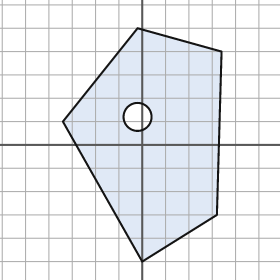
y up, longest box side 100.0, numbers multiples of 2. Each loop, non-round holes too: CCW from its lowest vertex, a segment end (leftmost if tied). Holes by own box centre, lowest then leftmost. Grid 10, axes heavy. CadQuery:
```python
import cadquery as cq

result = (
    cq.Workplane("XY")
    .moveTo(0.0, -50.0)
    .lineTo(32.0, -30.0)
    .lineTo(34.0, 40.0)
    .lineTo(-2.0, 50.0)
    .lineTo(-34.0, 10.0)
    .close()
    .moveTo(-2.0, 12.0)
    .circle(6.0)
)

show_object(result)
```